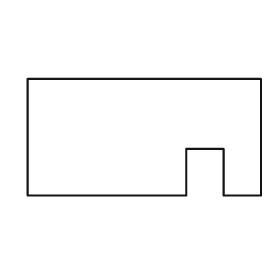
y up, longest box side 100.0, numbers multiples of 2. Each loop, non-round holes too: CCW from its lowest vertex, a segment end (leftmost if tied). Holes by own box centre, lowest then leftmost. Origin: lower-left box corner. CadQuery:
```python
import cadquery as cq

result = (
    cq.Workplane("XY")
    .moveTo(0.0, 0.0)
    .lineTo(68.0, 0.0)
    .lineTo(68.0, 20.0)
    .lineTo(84.0, 20.0)
    .lineTo(84.0, 0.0)
    .lineTo(100.0, 0.0)
    .lineTo(100.0, 50.0)
    .lineTo(0.0, 50.0)
    .close()
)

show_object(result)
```